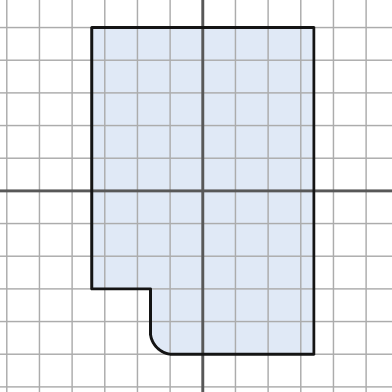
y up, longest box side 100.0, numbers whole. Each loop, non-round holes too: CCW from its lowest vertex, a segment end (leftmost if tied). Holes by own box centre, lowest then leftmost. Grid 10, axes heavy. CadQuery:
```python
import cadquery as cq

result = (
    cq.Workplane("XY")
    .moveTo(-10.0, -50.0)
    .lineTo(34.0, -50.0)
    .lineTo(34.0, 50.0)
    .lineTo(-34.0, 50.0)
    .lineTo(-34.0, -30.0)
    .lineTo(-16.0, -30.0)
    .lineTo(-16.0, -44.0)
    .threePointArc((-14.0, -48.0), (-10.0, -50.0))
    .close()
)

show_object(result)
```